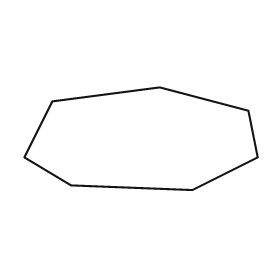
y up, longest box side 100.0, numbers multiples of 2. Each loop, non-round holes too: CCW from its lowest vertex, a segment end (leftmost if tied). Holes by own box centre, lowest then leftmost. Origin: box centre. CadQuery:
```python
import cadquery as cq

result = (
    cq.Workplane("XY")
    .moveTo(22.0, -22.0)
    .lineTo(50.0, -8.0)
    .lineTo(46.0, 12.0)
    .lineTo(8.0, 22.0)
    .lineTo(-38.0, 16.0)
    .lineTo(-50.0, -8.0)
    .lineTo(-30.0, -20.0)
    .close()
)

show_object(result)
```